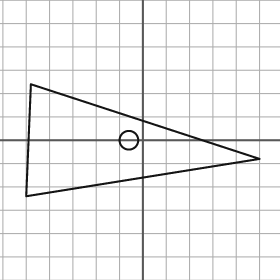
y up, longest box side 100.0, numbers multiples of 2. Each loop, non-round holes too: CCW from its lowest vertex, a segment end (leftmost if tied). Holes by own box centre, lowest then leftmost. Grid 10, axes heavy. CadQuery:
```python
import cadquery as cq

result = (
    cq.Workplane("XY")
    .moveTo(-50.0, -24.0)
    .lineTo(50.0, -8.0)
    .lineTo(-48.0, 24.0)
    .close()
    .moveTo(-6.0, 0.0)
    .circle(4.0)
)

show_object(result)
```